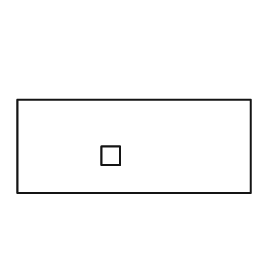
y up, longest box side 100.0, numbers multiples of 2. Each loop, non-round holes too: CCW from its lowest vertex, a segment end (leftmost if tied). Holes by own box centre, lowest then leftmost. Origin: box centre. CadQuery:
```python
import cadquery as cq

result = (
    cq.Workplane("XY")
    .moveTo(-50.0, -20.0)
    .lineTo(50.0, -20.0)
    .lineTo(50.0, 20.0)
    .lineTo(-50.0, 20.0)
    .close()
    .moveTo(-14.0, -8.0)
    .lineTo(-6.0, -8.0)
    .lineTo(-6.0, 0.0)
    .lineTo(-14.0, 0.0)
    .close()
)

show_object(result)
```